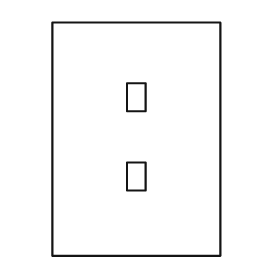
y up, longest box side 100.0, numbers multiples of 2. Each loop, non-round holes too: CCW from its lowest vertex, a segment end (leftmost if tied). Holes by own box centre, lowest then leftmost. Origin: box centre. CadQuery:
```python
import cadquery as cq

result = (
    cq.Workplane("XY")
    .moveTo(-36.0, -50.0)
    .lineTo(36.0, -50.0)
    .lineTo(36.0, 50.0)
    .lineTo(-36.0, 50.0)
    .close()
    .moveTo(-4.0, -22.0)
    .lineTo(4.0, -22.0)
    .lineTo(4.0, -10.0)
    .lineTo(-4.0, -10.0)
    .close()
    .moveTo(-4.0, 12.0)
    .lineTo(4.0, 12.0)
    .lineTo(4.0, 24.0)
    .lineTo(-4.0, 24.0)
    .close()
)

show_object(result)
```